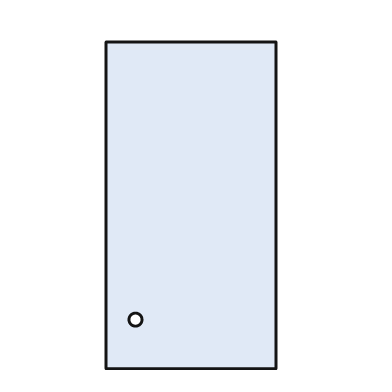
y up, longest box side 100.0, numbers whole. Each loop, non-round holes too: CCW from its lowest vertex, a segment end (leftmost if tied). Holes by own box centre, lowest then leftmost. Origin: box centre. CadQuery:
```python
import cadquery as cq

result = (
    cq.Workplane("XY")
    .moveTo(-26.0, -50.0)
    .lineTo(26.0, -50.0)
    .lineTo(26.0, 50.0)
    .lineTo(-26.0, 50.0)
    .close()
    .moveTo(-17.0, -35.0)
    .circle(2.0)
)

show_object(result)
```